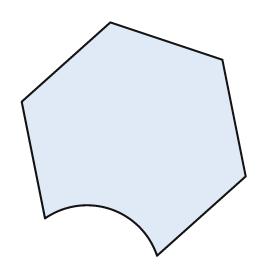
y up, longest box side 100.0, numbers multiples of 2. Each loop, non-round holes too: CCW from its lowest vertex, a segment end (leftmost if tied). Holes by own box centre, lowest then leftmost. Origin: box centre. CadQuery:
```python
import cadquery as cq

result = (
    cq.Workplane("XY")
    .moveTo(10.0, -50.0)
    .lineTo(48.0, -16.0)
    .lineTo(38.0, 34.0)
    .lineTo(-10.0, 50.0)
    .lineTo(-48.0, 16.0)
    .lineTo(-38.0, -34.0)
    .threePointArc((-10.0, -30.0), (10.0, -50.0))
    .close()
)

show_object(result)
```